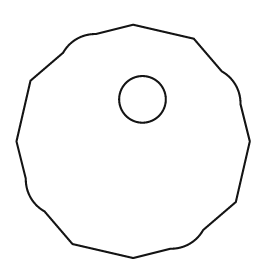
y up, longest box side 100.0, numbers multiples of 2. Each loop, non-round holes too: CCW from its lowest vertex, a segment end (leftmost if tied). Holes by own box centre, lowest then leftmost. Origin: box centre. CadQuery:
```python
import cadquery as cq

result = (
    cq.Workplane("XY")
    .moveTo(0.0, -50.0)
    .lineTo(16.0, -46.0)
    .threePointArc((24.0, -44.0), (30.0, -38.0))
    .lineTo(44.0, -26.0)
    .lineTo(50.0, 0.0)
    .lineTo(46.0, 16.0)
    .threePointArc((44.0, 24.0), (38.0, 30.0))
    .lineTo(26.0, 44.0)
    .lineTo(0.0, 50.0)
    .lineTo(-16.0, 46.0)
    .threePointArc((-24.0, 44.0), (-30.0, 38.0))
    .lineTo(-44.0, 26.0)
    .lineTo(-50.0, 0.0)
    .lineTo(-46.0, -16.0)
    .threePointArc((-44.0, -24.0), (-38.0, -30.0))
    .lineTo(-26.0, -44.0)
    .close()
    .moveTo(4.0, 18.0)
    .circle(10.0)
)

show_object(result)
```